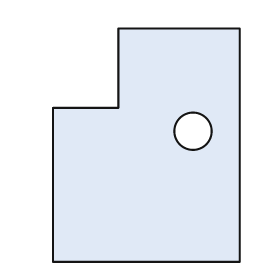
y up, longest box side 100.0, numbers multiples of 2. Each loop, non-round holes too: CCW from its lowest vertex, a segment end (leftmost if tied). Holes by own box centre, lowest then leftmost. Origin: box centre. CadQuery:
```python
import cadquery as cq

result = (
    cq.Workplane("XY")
    .moveTo(-40.0, -50.0)
    .lineTo(40.0, -50.0)
    .lineTo(40.0, 50.0)
    .lineTo(-12.0, 50.0)
    .lineTo(-12.0, 16.0)
    .lineTo(-40.0, 16.0)
    .close()
    .moveTo(20.0, 6.0)
    .circle(8.0)
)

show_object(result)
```